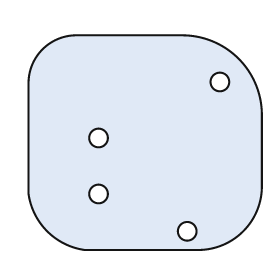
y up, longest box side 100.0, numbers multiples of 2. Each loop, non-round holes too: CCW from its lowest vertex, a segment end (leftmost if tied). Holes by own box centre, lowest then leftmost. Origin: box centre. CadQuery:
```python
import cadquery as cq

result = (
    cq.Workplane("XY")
    .moveTo(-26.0, -46.0)
    .lineTo(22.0, -46.0)
    .threePointArc((42.0, -38.0), (50.0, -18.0))
    .lineTo(50.0, 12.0)
    .threePointArc((40.0, 36.0), (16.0, 46.0))
    .lineTo(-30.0, 46.0)
    .threePointArc((-44.0, 40.0), (-50.0, 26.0))
    .lineTo(-50.0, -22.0)
    .threePointArc((-42.0, -38.0), (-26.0, -46.0))
    .close()
    .moveTo(18.0, -38.0)
    .circle(4.0)
    .moveTo(-20.0, -22.0)
    .circle(4.0)
    .moveTo(-20.0, 2.0)
    .circle(4.0)
    .moveTo(32.0, 26.0)
    .circle(4.0)
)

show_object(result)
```